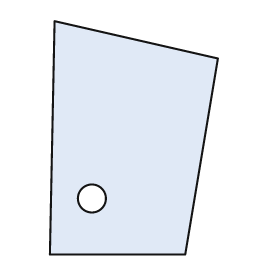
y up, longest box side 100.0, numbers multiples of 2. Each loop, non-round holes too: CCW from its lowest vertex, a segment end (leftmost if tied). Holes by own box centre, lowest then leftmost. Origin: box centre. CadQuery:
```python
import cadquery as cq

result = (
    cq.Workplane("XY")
    .moveTo(-36.0, -50.0)
    .lineTo(22.0, -50.0)
    .lineTo(36.0, 34.0)
    .lineTo(-34.0, 50.0)
    .close()
    .moveTo(-18.0, -26.0)
    .circle(6.0)
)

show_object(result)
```